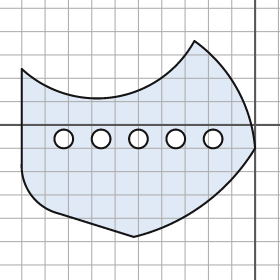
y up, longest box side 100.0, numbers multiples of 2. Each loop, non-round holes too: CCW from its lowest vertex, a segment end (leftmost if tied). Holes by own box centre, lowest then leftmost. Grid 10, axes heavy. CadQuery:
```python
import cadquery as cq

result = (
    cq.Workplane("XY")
    .moveTo(-52.0, -48.0)
    .threePointArc((-22.0, -34.0), (0.0, -10.0))
    .threePointArc((-8.0, 16.0), (-26.0, 36.0))
    .threePointArc((-60.0, 12.0), (-100.0, 24.0))
    .lineTo(-100.0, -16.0)
    .threePointArc((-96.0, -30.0), (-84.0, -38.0))
    .close()
    .moveTo(-82.0, -6.0)
    .circle(4.0)
    .moveTo(-66.0, -6.0)
    .circle(4.0)
    .moveTo(-50.0, -6.0)
    .circle(4.0)
    .moveTo(-34.0, -6.0)
    .circle(4.0)
    .moveTo(-18.0, -6.0)
    .circle(4.0)
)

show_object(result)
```